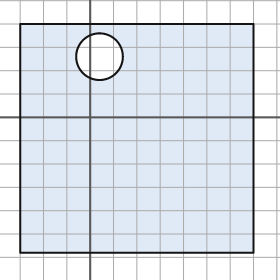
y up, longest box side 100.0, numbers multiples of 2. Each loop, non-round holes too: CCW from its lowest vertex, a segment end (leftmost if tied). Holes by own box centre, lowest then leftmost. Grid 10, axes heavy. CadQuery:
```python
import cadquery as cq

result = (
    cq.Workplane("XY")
    .moveTo(-30.0, -58.0)
    .lineTo(70.0, -58.0)
    .lineTo(70.0, 40.0)
    .lineTo(-30.0, 40.0)
    .close()
    .moveTo(4.0, 26.0)
    .circle(10.0)
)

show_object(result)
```